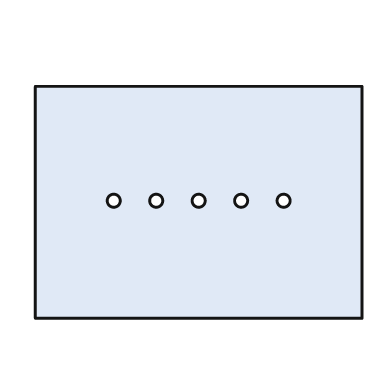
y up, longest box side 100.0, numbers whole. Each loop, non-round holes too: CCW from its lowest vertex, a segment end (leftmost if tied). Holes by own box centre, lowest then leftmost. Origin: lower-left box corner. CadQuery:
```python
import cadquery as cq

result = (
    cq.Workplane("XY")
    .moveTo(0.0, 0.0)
    .lineTo(100.0, 0.0)
    .lineTo(100.0, 71.0)
    .lineTo(0.0, 71.0)
    .close()
    .moveTo(24.0, 36.0)
    .circle(2.0)
    .moveTo(37.0, 36.0)
    .circle(2.0)
    .moveTo(50.0, 36.0)
    .circle(2.0)
    .moveTo(63.0, 36.0)
    .circle(2.0)
    .moveTo(76.0, 36.0)
    .circle(2.0)
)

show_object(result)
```